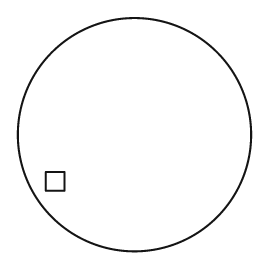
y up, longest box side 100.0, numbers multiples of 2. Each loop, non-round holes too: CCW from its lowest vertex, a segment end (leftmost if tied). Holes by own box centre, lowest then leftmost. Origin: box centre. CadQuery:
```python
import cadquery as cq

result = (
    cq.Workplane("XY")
    .moveTo(0.0, 0.0)
    .circle(50.0)
    .moveTo(-38.0, -24.0)
    .lineTo(-30.0, -24.0)
    .lineTo(-30.0, -16.0)
    .lineTo(-38.0, -16.0)
    .close()
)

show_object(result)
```